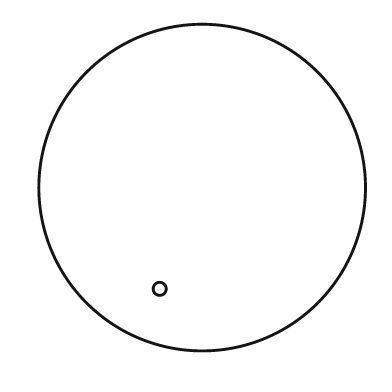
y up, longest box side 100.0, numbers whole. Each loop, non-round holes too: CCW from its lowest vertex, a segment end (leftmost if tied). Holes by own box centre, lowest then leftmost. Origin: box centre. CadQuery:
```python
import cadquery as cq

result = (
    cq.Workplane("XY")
    .moveTo(0.0, 0.0)
    .circle(50.0)
    .moveTo(-13.0, -31.0)
    .circle(2.0)
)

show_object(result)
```